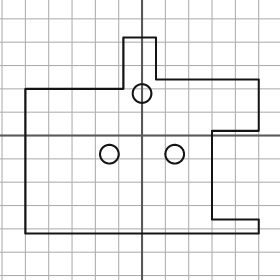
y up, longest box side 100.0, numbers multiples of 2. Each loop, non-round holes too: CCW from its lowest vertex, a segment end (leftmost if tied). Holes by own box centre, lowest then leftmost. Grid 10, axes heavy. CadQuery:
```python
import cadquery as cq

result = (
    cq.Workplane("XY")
    .moveTo(-50.0, -42.0)
    .lineTo(50.0, -42.0)
    .lineTo(50.0, -36.0)
    .lineTo(30.0, -36.0)
    .lineTo(30.0, 2.0)
    .lineTo(50.0, 2.0)
    .lineTo(50.0, 24.0)
    .lineTo(6.0, 24.0)
    .lineTo(6.0, 42.0)
    .lineTo(-8.0, 42.0)
    .lineTo(-8.0, 20.0)
    .lineTo(-50.0, 20.0)
    .close()
    .moveTo(-14.0, -8.0)
    .circle(4.0)
    .moveTo(14.0, -8.0)
    .circle(4.0)
    .moveTo(0.0, 18.0)
    .circle(4.0)
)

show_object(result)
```